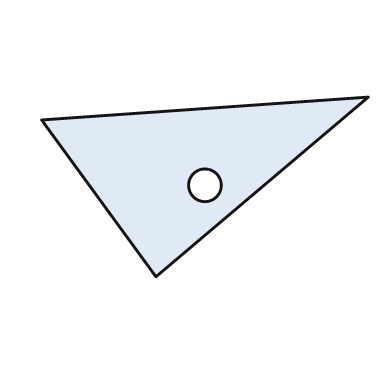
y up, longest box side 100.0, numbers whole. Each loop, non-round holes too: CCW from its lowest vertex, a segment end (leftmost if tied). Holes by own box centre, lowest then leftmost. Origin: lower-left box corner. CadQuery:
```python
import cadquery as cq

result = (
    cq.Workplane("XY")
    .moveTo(35.0, 0.0)
    .lineTo(100.0, 55.0)
    .lineTo(0.0, 48.0)
    .close()
    .moveTo(50.0, 28.0)
    .circle(5.0)
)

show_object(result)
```